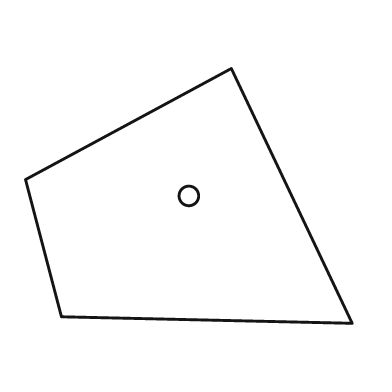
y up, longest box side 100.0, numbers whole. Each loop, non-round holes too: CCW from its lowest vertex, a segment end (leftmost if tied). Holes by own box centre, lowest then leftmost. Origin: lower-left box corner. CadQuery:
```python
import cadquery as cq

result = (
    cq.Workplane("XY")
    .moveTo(100.0, 0.0)
    .lineTo(63.0, 78.0)
    .lineTo(0.0, 44.0)
    .lineTo(11.0, 2.0)
    .close()
    .moveTo(50.0, 39.0)
    .circle(3.0)
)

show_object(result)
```